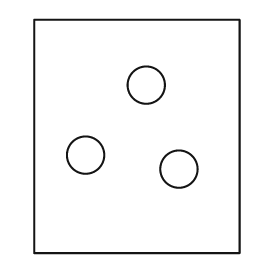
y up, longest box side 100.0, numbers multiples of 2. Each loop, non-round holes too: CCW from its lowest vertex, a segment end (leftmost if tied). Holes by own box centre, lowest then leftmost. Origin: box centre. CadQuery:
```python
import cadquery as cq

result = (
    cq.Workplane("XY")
    .moveTo(-44.0, -50.0)
    .lineTo(44.0, -50.0)
    .lineTo(44.0, 50.0)
    .lineTo(-44.0, 50.0)
    .close()
    .moveTo(18.0, -14.0)
    .circle(8.0)
    .moveTo(-22.0, -8.0)
    .circle(8.0)
    .moveTo(4.0, 22.0)
    .circle(8.0)
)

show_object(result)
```